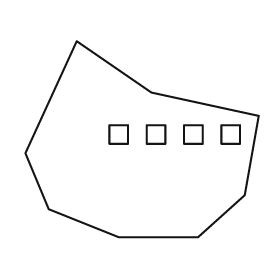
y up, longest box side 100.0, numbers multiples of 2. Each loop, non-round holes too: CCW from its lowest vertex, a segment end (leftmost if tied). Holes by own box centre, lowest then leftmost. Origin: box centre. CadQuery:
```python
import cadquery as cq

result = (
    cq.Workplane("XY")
    .moveTo(-10.0, -42.0)
    .lineTo(24.0, -42.0)
    .lineTo(44.0, -24.0)
    .lineTo(50.0, 10.0)
    .lineTo(4.0, 20.0)
    .lineTo(-28.0, 42.0)
    .lineTo(-50.0, -6.0)
    .lineTo(-40.0, -30.0)
    .close()
    .moveTo(-14.0, -2.0)
    .lineTo(-6.0, -2.0)
    .lineTo(-6.0, 6.0)
    .lineTo(-14.0, 6.0)
    .close()
    .moveTo(2.0, -2.0)
    .lineTo(10.0, -2.0)
    .lineTo(10.0, 6.0)
    .lineTo(2.0, 6.0)
    .close()
    .moveTo(18.0, -2.0)
    .lineTo(26.0, -2.0)
    .lineTo(26.0, 6.0)
    .lineTo(18.0, 6.0)
    .close()
    .moveTo(34.0, -2.0)
    .lineTo(42.0, -2.0)
    .lineTo(42.0, 6.0)
    .lineTo(34.0, 6.0)
    .close()
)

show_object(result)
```